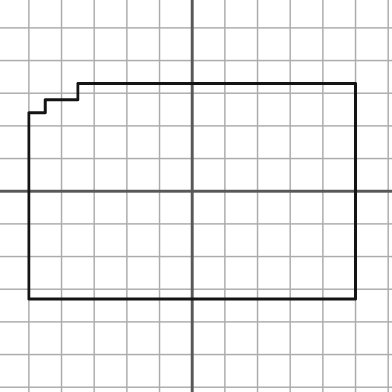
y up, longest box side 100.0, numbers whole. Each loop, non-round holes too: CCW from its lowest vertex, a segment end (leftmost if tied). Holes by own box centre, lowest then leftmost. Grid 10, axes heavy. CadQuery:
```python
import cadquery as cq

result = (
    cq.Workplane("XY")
    .moveTo(-50.0, -33.0)
    .lineTo(50.0, -33.0)
    .lineTo(50.0, 33.0)
    .lineTo(-35.0, 33.0)
    .lineTo(-35.0, 28.0)
    .lineTo(-45.0, 28.0)
    .lineTo(-45.0, 24.0)
    .lineTo(-50.0, 24.0)
    .close()
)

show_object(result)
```